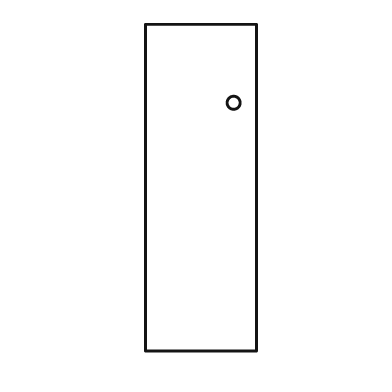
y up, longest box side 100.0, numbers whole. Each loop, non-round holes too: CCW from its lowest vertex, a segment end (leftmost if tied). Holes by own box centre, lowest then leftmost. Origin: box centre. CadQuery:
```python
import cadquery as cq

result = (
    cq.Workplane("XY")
    .moveTo(-17.0, -50.0)
    .lineTo(17.0, -50.0)
    .lineTo(17.0, 50.0)
    .lineTo(-17.0, 50.0)
    .close()
    .moveTo(10.0, 26.0)
    .circle(2.0)
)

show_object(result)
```